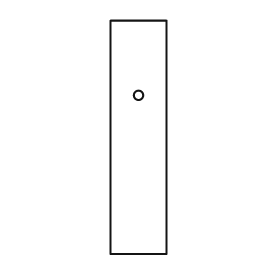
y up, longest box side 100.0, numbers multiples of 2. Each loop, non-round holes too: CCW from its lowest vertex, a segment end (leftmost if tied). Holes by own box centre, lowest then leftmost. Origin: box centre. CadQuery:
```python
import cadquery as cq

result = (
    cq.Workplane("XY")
    .moveTo(-12.0, -50.0)
    .lineTo(12.0, -50.0)
    .lineTo(12.0, 50.0)
    .lineTo(-12.0, 50.0)
    .close()
    .moveTo(0.0, 18.0)
    .circle(2.0)
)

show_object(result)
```